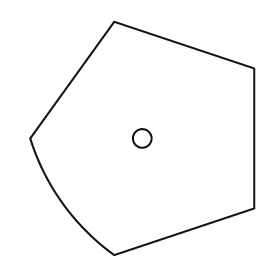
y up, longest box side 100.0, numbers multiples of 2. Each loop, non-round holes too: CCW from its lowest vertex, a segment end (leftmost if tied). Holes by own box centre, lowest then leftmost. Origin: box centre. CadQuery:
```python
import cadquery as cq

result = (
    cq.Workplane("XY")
    .moveTo(-12.0, -50.0)
    .lineTo(48.0, -30.0)
    .lineTo(48.0, 30.0)
    .lineTo(-12.0, 50.0)
    .lineTo(-48.0, 0.0)
    .threePointArc((-34.0, -28.0), (-12.0, -50.0))
    .close()
    .moveTo(0.0, 0.0)
    .circle(4.0)
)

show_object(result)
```